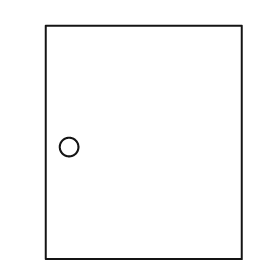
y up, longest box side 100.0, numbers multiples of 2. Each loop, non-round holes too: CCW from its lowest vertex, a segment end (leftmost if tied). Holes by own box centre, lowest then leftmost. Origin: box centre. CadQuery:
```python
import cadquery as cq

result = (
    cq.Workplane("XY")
    .moveTo(-42.0, -50.0)
    .lineTo(42.0, -50.0)
    .lineTo(42.0, 50.0)
    .lineTo(-42.0, 50.0)
    .close()
    .moveTo(-32.0, -2.0)
    .circle(4.0)
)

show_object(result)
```